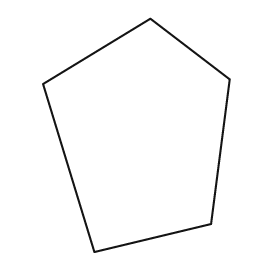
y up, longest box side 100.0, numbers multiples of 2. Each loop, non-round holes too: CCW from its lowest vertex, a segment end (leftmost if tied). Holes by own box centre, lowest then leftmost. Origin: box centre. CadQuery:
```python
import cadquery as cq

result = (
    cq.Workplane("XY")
    .moveTo(-18.0, -50.0)
    .lineTo(32.0, -38.0)
    .lineTo(40.0, 24.0)
    .lineTo(6.0, 50.0)
    .lineTo(-40.0, 22.0)
    .close()
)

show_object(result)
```